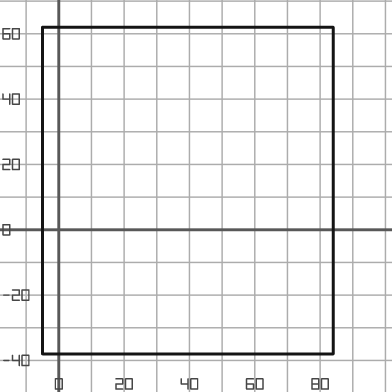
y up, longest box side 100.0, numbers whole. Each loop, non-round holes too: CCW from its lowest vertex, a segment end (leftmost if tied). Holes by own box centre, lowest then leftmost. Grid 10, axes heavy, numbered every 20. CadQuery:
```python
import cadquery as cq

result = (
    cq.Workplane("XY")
    .moveTo(-5.0, -38.0)
    .lineTo(84.0, -38.0)
    .lineTo(84.0, 62.0)
    .lineTo(-5.0, 62.0)
    .close()
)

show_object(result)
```